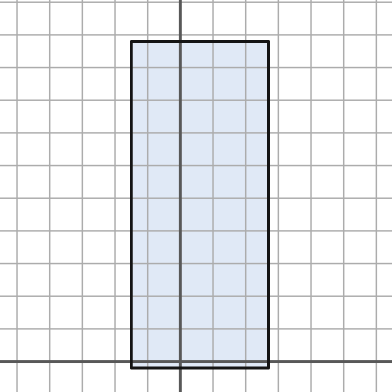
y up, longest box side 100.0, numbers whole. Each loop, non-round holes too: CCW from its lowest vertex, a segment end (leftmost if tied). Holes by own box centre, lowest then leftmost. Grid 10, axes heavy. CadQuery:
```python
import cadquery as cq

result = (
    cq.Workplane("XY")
    .moveTo(-15.0, -2.0)
    .lineTo(27.0, -2.0)
    .lineTo(27.0, 98.0)
    .lineTo(-15.0, 98.0)
    .close()
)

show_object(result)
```